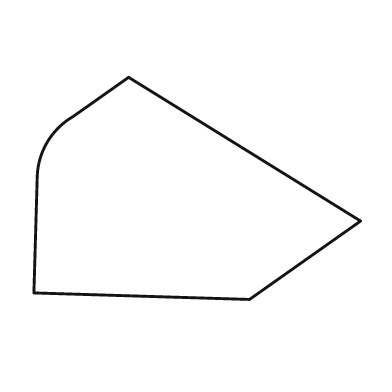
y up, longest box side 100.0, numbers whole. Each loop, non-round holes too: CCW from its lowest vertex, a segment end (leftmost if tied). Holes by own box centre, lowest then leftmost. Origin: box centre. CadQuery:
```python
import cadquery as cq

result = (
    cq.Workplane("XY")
    .moveTo(16.0, -34.0)
    .lineTo(50.0, -10.0)
    .lineTo(-21.0, 34.0)
    .lineTo(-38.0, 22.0)
    .threePointArc((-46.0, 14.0), (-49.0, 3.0))
    .lineTo(-50.0, -32.0)
    .close()
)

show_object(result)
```